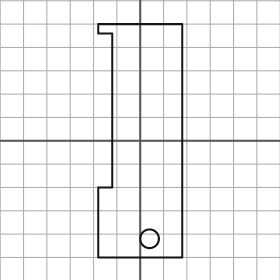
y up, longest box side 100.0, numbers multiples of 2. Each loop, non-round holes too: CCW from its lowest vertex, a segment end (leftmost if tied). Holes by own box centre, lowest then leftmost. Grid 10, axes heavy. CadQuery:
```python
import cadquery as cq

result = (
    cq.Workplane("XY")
    .moveTo(-18.0, -50.0)
    .lineTo(18.0, -50.0)
    .lineTo(18.0, 50.0)
    .lineTo(-18.0, 50.0)
    .lineTo(-18.0, 46.0)
    .lineTo(-12.0, 46.0)
    .lineTo(-12.0, -20.0)
    .lineTo(-18.0, -20.0)
    .close()
    .moveTo(4.0, -42.0)
    .circle(4.0)
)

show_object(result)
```